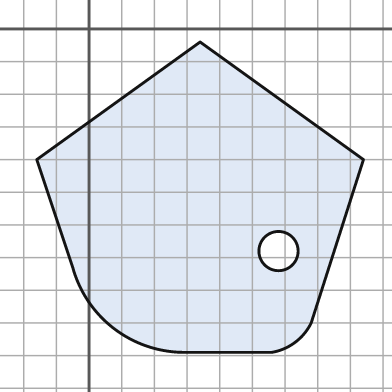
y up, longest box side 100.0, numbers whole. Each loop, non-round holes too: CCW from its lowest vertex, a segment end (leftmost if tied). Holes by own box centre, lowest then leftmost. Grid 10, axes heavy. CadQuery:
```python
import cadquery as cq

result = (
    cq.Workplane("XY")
    .moveTo(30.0, -99.0)
    .lineTo(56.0, -99.0)
    .threePointArc((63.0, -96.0), (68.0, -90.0))
    .lineTo(84.0, -40.0)
    .lineTo(34.0, -4.0)
    .lineTo(-16.0, -40.0)
    .lineTo(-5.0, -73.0)
    .threePointArc((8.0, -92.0), (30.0, -99.0))
    .close()
    .moveTo(58.0, -68.0)
    .circle(6.0)
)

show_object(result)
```